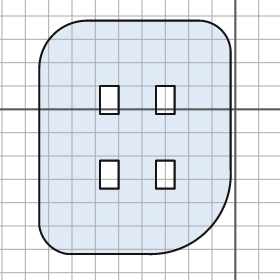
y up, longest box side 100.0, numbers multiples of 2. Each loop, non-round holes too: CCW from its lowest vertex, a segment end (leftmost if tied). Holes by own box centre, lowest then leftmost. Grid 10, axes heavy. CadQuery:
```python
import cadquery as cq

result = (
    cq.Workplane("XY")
    .moveTo(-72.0, -62.0)
    .lineTo(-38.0, -62.0)
    .threePointArc((-12.0, -52.0), (-2.0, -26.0))
    .lineTo(-2.0, 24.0)
    .threePointArc((-6.0, 34.0), (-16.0, 38.0))
    .lineTo(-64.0, 38.0)
    .threePointArc((-78.0, 32.0), (-84.0, 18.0))
    .lineTo(-84.0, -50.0)
    .threePointArc((-80.0, -58.0), (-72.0, -62.0))
    .close()
    .moveTo(-58.0, -34.0)
    .lineTo(-50.0, -34.0)
    .lineTo(-50.0, -22.0)
    .lineTo(-58.0, -22.0)
    .close()
    .moveTo(-34.0, -34.0)
    .lineTo(-26.0, -34.0)
    .lineTo(-26.0, -22.0)
    .lineTo(-34.0, -22.0)
    .close()
    .moveTo(-58.0, -2.0)
    .lineTo(-50.0, -2.0)
    .lineTo(-50.0, 10.0)
    .lineTo(-58.0, 10.0)
    .close()
    .moveTo(-34.0, -2.0)
    .lineTo(-26.0, -2.0)
    .lineTo(-26.0, 10.0)
    .lineTo(-34.0, 10.0)
    .close()
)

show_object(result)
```